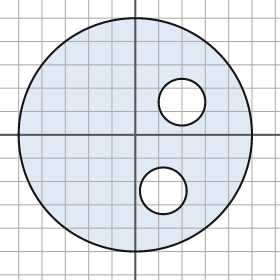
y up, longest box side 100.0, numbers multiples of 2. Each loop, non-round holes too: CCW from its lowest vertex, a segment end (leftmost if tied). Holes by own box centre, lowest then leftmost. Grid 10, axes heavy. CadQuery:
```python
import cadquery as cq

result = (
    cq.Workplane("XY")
    .moveTo(0.0, 0.0)
    .circle(50.0)
    .moveTo(12.0, -24.0)
    .circle(10.0)
    .moveTo(20.0, 14.0)
    .circle(10.0)
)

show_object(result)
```